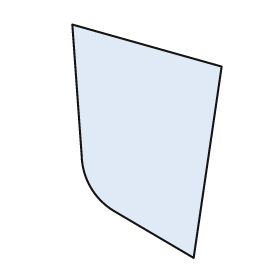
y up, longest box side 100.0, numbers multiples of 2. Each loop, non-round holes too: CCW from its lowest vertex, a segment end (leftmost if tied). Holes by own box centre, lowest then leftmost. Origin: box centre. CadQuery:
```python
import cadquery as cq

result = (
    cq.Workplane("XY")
    .moveTo(20.0, -50.0)
    .lineTo(32.0, 32.0)
    .lineTo(-32.0, 50.0)
    .lineTo(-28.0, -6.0)
    .threePointArc((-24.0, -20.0), (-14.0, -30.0))
    .close()
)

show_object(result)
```